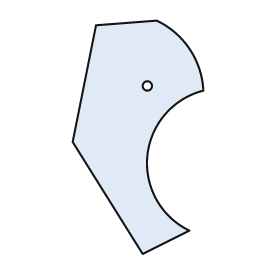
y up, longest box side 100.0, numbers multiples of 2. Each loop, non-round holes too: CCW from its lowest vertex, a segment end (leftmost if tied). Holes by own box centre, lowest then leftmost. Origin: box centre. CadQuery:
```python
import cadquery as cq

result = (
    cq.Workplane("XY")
    .moveTo(2.0, -50.0)
    .lineTo(22.0, -40.0)
    .threePointArc((4.0, -8.0), (28.0, 20.0))
    .threePointArc((22.0, 38.0), (8.0, 50.0))
    .lineTo(-18.0, 48.0)
    .lineTo(-28.0, -2.0)
    .close()
    .moveTo(4.0, 22.0)
    .circle(2.0)
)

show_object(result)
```